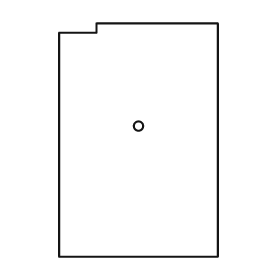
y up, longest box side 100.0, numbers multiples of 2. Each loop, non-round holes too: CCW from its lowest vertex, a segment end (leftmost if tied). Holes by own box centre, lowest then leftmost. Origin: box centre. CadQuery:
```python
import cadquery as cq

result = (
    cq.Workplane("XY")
    .moveTo(-34.0, -50.0)
    .lineTo(34.0, -50.0)
    .lineTo(34.0, 50.0)
    .lineTo(-18.0, 50.0)
    .lineTo(-18.0, 46.0)
    .lineTo(-34.0, 46.0)
    .close()
    .moveTo(0.0, 6.0)
    .circle(2.0)
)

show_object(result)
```